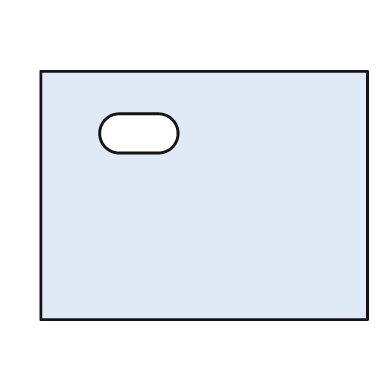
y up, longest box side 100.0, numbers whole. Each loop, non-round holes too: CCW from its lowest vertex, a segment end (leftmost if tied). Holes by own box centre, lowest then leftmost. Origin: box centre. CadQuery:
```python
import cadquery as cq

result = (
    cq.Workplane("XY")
    .moveTo(-50.0, -38.0)
    .lineTo(50.0, -38.0)
    .lineTo(50.0, 38.0)
    .lineTo(-50.0, 38.0)
    .close()
    .moveTo(-26.0, 13.0)
    .lineTo(-14.0, 13.0)
    .threePointArc((-8.0, 19.0), (-14.0, 25.0))
    .lineTo(-26.0, 25.0)
    .threePointArc((-32.0, 19.0), (-26.0, 13.0))
    .close()
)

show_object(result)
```